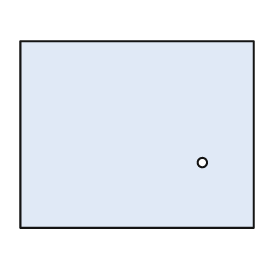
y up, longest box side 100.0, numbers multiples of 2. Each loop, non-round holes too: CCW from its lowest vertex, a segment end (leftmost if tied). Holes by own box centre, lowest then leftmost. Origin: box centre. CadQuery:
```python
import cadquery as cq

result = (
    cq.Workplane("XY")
    .moveTo(-50.0, -40.0)
    .lineTo(50.0, -40.0)
    .lineTo(50.0, 40.0)
    .lineTo(-50.0, 40.0)
    .close()
    .moveTo(28.0, -12.0)
    .circle(2.0)
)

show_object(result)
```